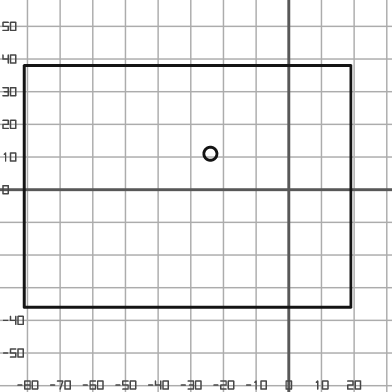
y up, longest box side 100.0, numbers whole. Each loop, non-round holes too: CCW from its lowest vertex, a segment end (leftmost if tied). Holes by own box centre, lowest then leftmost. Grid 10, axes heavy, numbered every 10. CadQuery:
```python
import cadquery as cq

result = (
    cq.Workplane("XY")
    .moveTo(-81.0, -36.0)
    .lineTo(19.0, -36.0)
    .lineTo(19.0, 38.0)
    .lineTo(-81.0, 38.0)
    .close()
    .moveTo(-24.0, 11.0)
    .circle(2.0)
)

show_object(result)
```